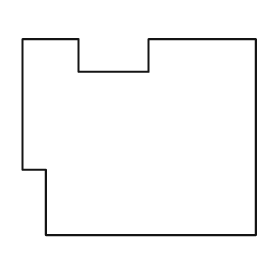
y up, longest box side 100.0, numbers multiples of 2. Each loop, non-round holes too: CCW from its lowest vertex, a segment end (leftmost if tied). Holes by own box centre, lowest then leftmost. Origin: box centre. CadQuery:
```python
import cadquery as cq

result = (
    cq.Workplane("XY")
    .moveTo(-40.0, -42.0)
    .lineTo(50.0, -42.0)
    .lineTo(50.0, 42.0)
    .lineTo(4.0, 42.0)
    .lineTo(4.0, 28.0)
    .lineTo(-26.0, 28.0)
    .lineTo(-26.0, 42.0)
    .lineTo(-50.0, 42.0)
    .lineTo(-50.0, -14.0)
    .lineTo(-40.0, -14.0)
    .close()
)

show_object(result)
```